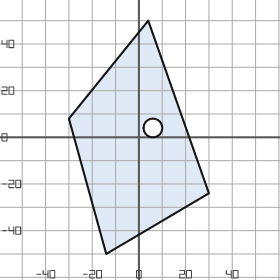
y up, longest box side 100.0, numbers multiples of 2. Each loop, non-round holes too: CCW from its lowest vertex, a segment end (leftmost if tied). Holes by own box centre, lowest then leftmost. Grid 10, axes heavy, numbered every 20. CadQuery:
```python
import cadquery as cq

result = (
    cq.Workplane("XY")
    .moveTo(-14.0, -50.0)
    .lineTo(30.0, -24.0)
    .lineTo(4.0, 50.0)
    .lineTo(-30.0, 8.0)
    .close()
    .moveTo(6.0, 4.0)
    .circle(4.0)
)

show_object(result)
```